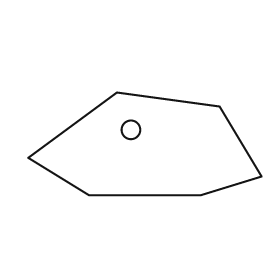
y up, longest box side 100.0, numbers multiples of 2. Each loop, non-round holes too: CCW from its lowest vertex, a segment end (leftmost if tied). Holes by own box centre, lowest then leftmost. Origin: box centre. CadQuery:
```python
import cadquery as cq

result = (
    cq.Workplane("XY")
    .moveTo(-24.0, -22.0)
    .lineTo(24.0, -22.0)
    .lineTo(50.0, -14.0)
    .lineTo(32.0, 16.0)
    .lineTo(-12.0, 22.0)
    .lineTo(-50.0, -6.0)
    .close()
    .moveTo(-6.0, 6.0)
    .circle(4.0)
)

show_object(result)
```